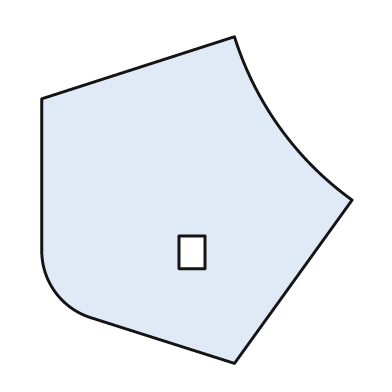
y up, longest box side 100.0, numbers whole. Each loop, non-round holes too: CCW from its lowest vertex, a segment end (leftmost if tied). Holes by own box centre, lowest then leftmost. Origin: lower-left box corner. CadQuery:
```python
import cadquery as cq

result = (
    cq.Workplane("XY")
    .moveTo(59.0, 0.0)
    .lineTo(95.0, 50.0)
    .threePointArc((73.0, 72.0), (59.0, 100.0))
    .lineTo(0.0, 81.0)
    .lineTo(0.0, 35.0)
    .threePointArc((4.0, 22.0), (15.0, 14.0))
    .close()
    .moveTo(42.0, 29.0)
    .lineTo(50.0, 29.0)
    .lineTo(50.0, 39.0)
    .lineTo(42.0, 39.0)
    .close()
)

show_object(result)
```